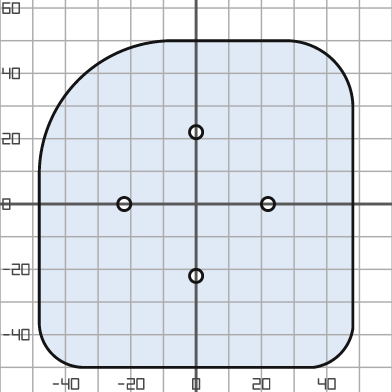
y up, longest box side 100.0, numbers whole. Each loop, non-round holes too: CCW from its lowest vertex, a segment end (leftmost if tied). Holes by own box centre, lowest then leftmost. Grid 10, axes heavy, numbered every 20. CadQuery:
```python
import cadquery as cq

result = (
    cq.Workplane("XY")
    .moveTo(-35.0, -50.0)
    .lineTo(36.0, -50.0)
    .threePointArc((44.0, -46.0), (48.0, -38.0))
    .lineTo(48.0, 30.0)
    .threePointArc((42.0, 44.0), (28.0, 50.0))
    .lineTo(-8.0, 50.0)
    .threePointArc((-36.0, 38.0), (-48.0, 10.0))
    .lineTo(-48.0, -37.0)
    .threePointArc((-44.0, -46.0), (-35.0, -50.0))
    .close()
    .moveTo(0.0, -22.0)
    .circle(2.0)
    .moveTo(-22.0, 0.0)
    .circle(2.0)
    .moveTo(22.0, 0.0)
    .circle(2.0)
    .moveTo(0.0, 22.0)
    .circle(2.0)
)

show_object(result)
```